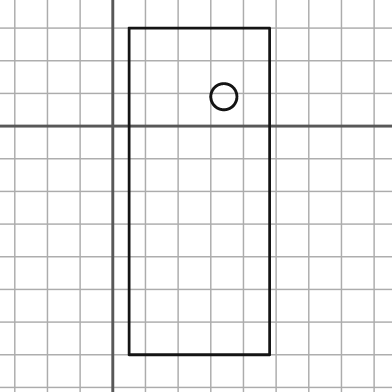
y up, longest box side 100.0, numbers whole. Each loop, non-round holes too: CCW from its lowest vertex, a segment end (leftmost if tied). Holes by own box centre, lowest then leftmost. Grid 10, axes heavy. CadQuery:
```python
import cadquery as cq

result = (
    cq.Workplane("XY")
    .moveTo(5.0, -70.0)
    .lineTo(48.0, -70.0)
    .lineTo(48.0, 30.0)
    .lineTo(5.0, 30.0)
    .close()
    .moveTo(34.0, 9.0)
    .circle(4.0)
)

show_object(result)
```